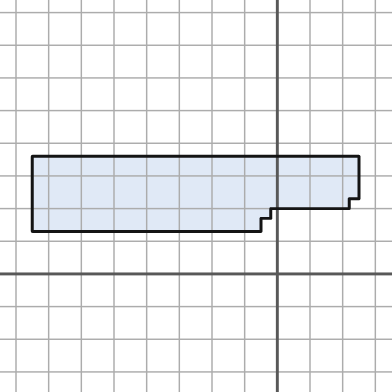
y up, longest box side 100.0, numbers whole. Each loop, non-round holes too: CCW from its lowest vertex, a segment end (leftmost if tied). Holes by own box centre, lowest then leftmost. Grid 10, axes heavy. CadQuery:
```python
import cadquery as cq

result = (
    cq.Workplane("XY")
    .moveTo(-75.0, 13.0)
    .lineTo(-5.0, 13.0)
    .lineTo(-5.0, 17.0)
    .lineTo(-2.0, 17.0)
    .lineTo(-2.0, 20.0)
    .lineTo(22.0, 20.0)
    .lineTo(22.0, 23.0)
    .lineTo(25.0, 23.0)
    .lineTo(25.0, 36.0)
    .lineTo(-75.0, 36.0)
    .close()
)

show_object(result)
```